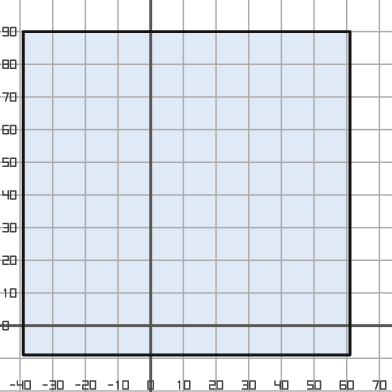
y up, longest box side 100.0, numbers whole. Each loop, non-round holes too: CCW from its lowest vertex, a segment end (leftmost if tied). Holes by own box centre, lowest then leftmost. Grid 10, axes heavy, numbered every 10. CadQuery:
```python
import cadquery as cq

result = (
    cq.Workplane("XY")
    .moveTo(-39.0, -9.0)
    .lineTo(61.0, -9.0)
    .lineTo(61.0, 90.0)
    .lineTo(-39.0, 90.0)
    .close()
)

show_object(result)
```